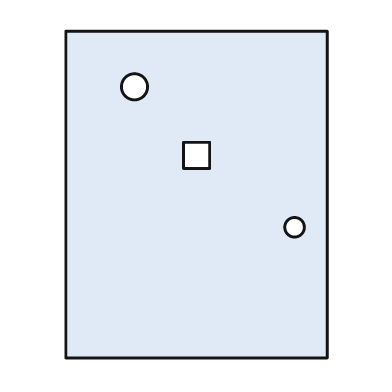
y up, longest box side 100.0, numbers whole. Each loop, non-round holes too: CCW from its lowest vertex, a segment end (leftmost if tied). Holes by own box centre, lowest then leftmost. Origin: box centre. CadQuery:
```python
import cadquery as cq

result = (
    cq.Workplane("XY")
    .moveTo(-40.0, -50.0)
    .lineTo(40.0, -50.0)
    .lineTo(40.0, 50.0)
    .lineTo(-40.0, 50.0)
    .close()
    .moveTo(30.0, -10.0)
    .circle(3.0)
    .moveTo(-4.0, 8.0)
    .lineTo(4.0, 8.0)
    .lineTo(4.0, 16.0)
    .lineTo(-4.0, 16.0)
    .close()
    .moveTo(-19.0, 33.0)
    .circle(4.0)
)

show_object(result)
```